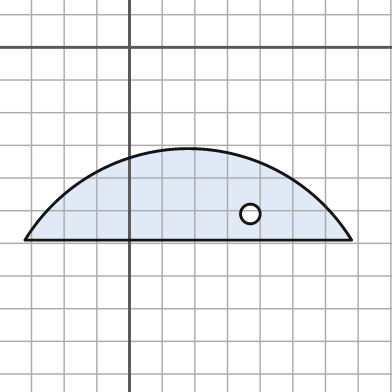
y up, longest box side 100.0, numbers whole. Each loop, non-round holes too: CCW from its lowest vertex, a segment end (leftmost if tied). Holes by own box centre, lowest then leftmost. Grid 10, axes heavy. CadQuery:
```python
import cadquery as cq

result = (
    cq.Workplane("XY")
    .moveTo(-32.0, -59.0)
    .lineTo(68.0, -59.0)
    .threePointArc((18.0, -31.0), (-32.0, -59.0))
    .close()
    .moveTo(37.0, -51.0)
    .circle(3.0)
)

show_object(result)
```